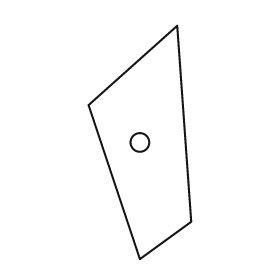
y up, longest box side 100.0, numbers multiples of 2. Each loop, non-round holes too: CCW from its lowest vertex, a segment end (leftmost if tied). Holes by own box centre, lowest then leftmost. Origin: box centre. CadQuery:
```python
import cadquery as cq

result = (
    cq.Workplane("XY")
    .moveTo(0.0, -50.0)
    .lineTo(22.0, -34.0)
    .lineTo(16.0, 50.0)
    .lineTo(-22.0, 16.0)
    .close()
    .moveTo(0.0, 0.0)
    .circle(4.0)
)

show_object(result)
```